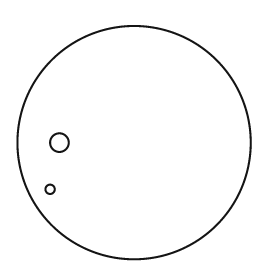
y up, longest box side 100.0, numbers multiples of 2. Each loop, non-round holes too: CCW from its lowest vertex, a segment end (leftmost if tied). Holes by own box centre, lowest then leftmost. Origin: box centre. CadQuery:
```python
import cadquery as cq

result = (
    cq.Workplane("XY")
    .moveTo(0.0, 0.0)
    .circle(50.0)
    .moveTo(-36.0, -20.0)
    .circle(2.0)
    .moveTo(-32.0, 0.0)
    .circle(4.0)
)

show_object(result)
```